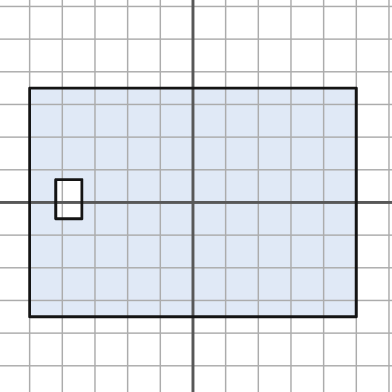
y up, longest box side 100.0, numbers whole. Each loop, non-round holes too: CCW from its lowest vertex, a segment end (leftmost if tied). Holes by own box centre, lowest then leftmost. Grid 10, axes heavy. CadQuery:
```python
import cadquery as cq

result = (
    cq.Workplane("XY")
    .moveTo(-50.0, -35.0)
    .lineTo(50.0, -35.0)
    .lineTo(50.0, 35.0)
    .lineTo(-50.0, 35.0)
    .close()
    .moveTo(-42.0, -5.0)
    .lineTo(-34.0, -5.0)
    .lineTo(-34.0, 7.0)
    .lineTo(-42.0, 7.0)
    .close()
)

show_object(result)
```